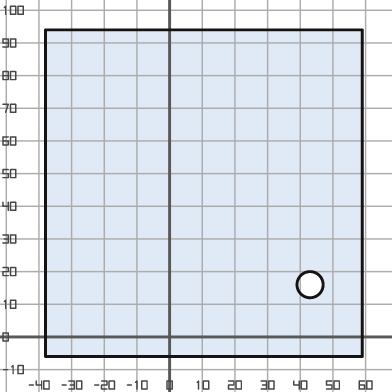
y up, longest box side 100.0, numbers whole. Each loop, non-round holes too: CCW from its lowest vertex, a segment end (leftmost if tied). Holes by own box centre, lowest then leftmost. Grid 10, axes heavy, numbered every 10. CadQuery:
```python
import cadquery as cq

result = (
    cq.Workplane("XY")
    .moveTo(-38.0, -6.0)
    .lineTo(59.0, -6.0)
    .lineTo(59.0, 94.0)
    .lineTo(-38.0, 94.0)
    .close()
    .moveTo(43.0, 16.0)
    .circle(4.0)
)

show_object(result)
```